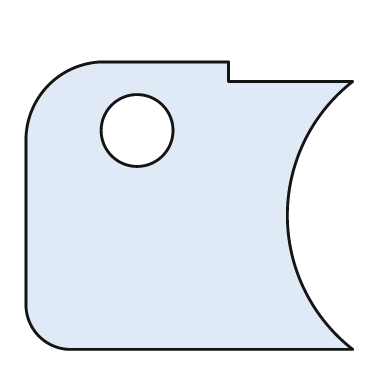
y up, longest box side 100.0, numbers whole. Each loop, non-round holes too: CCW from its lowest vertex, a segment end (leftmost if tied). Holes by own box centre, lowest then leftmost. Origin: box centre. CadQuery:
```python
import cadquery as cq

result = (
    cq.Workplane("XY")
    .moveTo(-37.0, -44.0)
    .lineTo(50.0, -44.0)
    .threePointArc((30.0, -3.0), (50.0, 38.0))
    .lineTo(12.0, 38.0)
    .lineTo(12.0, 44.0)
    .lineTo(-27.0, 44.0)
    .threePointArc((-43.0, 37.0), (-50.0, 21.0))
    .lineTo(-50.0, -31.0)
    .threePointArc((-46.0, -40.0), (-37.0, -44.0))
    .close()
    .moveTo(-16.0, 23.0)
    .circle(11.0)
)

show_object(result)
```